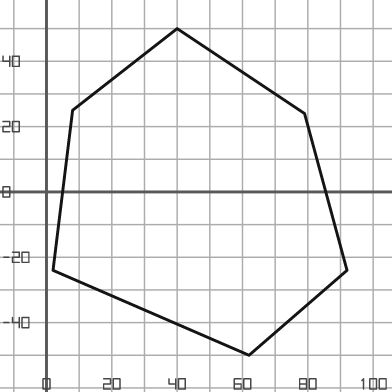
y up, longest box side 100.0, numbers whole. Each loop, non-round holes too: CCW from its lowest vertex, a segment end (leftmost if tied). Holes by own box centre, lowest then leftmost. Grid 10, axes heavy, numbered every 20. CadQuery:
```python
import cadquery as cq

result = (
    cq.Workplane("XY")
    .moveTo(62.0, -50.0)
    .lineTo(92.0, -24.0)
    .lineTo(79.0, 24.0)
    .lineTo(40.0, 50.0)
    .lineTo(8.0, 25.0)
    .lineTo(2.0, -24.0)
    .close()
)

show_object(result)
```